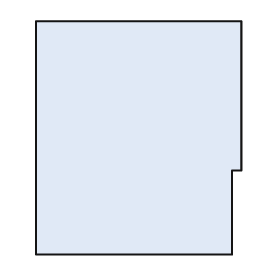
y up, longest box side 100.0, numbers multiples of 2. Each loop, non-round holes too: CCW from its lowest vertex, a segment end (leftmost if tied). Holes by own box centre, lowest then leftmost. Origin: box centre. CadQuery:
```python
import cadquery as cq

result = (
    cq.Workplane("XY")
    .moveTo(-44.0, -50.0)
    .lineTo(40.0, -50.0)
    .lineTo(40.0, -14.0)
    .lineTo(44.0, -14.0)
    .lineTo(44.0, 50.0)
    .lineTo(-44.0, 50.0)
    .close()
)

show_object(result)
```